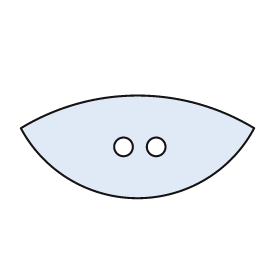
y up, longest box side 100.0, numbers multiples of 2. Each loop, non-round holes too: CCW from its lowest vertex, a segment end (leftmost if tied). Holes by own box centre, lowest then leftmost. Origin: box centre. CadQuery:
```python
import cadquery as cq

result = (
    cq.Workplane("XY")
    .moveTo(-50.0, 8.0)
    .threePointArc((0.0, -22.0), (50.0, 8.0))
    .threePointArc((0.0, 22.0), (-50.0, 8.0))
    .close()
    .moveTo(-6.0, 0.0)
    .circle(4.0)
    .moveTo(8.0, 0.0)
    .circle(4.0)
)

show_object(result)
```